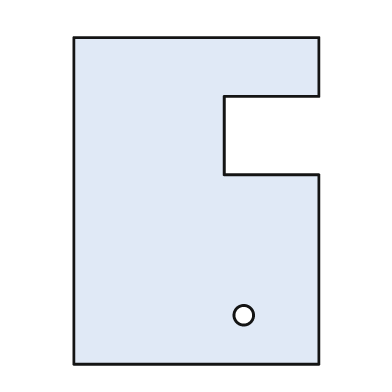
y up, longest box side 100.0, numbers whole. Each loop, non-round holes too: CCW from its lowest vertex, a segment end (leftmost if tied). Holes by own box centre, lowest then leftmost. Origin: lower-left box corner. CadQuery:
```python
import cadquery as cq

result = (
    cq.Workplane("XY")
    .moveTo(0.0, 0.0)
    .lineTo(75.0, 0.0)
    .lineTo(75.0, 58.0)
    .lineTo(46.0, 58.0)
    .lineTo(46.0, 82.0)
    .lineTo(75.0, 82.0)
    .lineTo(75.0, 100.0)
    .lineTo(0.0, 100.0)
    .close()
    .moveTo(52.0, 15.0)
    .circle(3.0)
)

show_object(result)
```